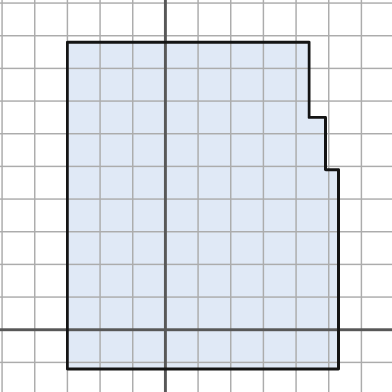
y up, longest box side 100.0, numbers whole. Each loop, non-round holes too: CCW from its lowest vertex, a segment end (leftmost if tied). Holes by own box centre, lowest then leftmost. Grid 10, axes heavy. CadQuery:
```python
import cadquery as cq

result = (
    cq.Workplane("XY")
    .moveTo(-30.0, -12.0)
    .lineTo(53.0, -12.0)
    .lineTo(53.0, 49.0)
    .lineTo(49.0, 49.0)
    .lineTo(49.0, 65.0)
    .lineTo(44.0, 65.0)
    .lineTo(44.0, 88.0)
    .lineTo(-30.0, 88.0)
    .close()
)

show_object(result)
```